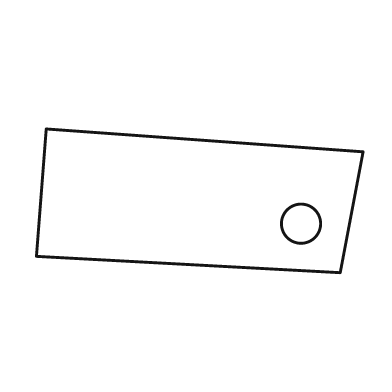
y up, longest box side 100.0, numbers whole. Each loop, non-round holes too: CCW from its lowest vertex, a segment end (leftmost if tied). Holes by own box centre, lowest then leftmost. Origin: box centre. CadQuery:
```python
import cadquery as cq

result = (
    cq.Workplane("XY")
    .moveTo(43.0, -22.0)
    .lineTo(50.0, 15.0)
    .lineTo(-47.0, 22.0)
    .lineTo(-50.0, -17.0)
    .close()
    .moveTo(31.0, -7.0)
    .circle(6.0)
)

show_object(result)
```